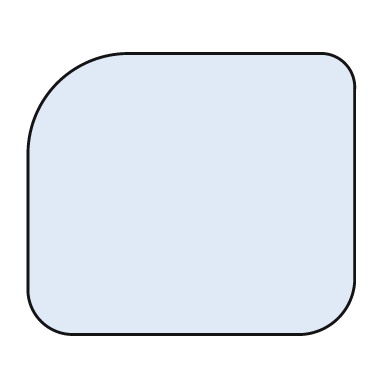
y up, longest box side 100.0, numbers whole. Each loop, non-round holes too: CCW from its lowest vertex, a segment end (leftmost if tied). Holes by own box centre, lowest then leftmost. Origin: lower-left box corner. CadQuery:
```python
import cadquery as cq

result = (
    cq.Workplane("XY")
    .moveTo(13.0, 0.0)
    .lineTo(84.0, 0.0)
    .threePointArc((95.0, 5.0), (100.0, 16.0))
    .lineTo(100.0, 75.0)
    .threePointArc((97.0, 83.0), (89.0, 86.0))
    .lineTo(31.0, 86.0)
    .threePointArc((9.0, 77.0), (0.0, 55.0))
    .lineTo(0.0, 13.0)
    .threePointArc((4.0, 4.0), (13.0, 0.0))
    .close()
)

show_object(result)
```